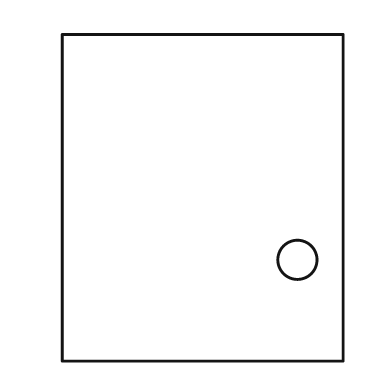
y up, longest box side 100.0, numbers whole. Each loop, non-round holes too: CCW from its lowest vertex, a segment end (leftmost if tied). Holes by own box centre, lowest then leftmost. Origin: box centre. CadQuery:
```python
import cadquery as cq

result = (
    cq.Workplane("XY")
    .moveTo(-43.0, -50.0)
    .lineTo(43.0, -50.0)
    .lineTo(43.0, 50.0)
    .lineTo(-43.0, 50.0)
    .close()
    .moveTo(29.0, -19.0)
    .circle(6.0)
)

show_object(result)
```